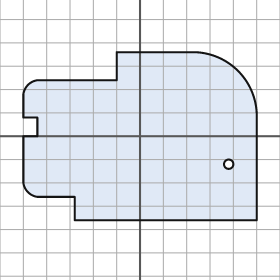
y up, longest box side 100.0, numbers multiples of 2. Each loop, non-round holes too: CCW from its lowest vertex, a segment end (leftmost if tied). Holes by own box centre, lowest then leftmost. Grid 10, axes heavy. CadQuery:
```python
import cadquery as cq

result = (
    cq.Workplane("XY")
    .moveTo(-28.0, -36.0)
    .lineTo(50.0, -36.0)
    .lineTo(50.0, 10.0)
    .threePointArc((42.0, 28.0), (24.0, 36.0))
    .lineTo(-10.0, 36.0)
    .lineTo(-10.0, 24.0)
    .lineTo(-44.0, 24.0)
    .threePointArc((-48.0, 22.0), (-50.0, 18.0))
    .lineTo(-50.0, 8.0)
    .lineTo(-44.0, 8.0)
    .lineTo(-44.0, 0.0)
    .lineTo(-50.0, 0.0)
    .lineTo(-50.0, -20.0)
    .threePointArc((-48.0, -24.0), (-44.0, -26.0))
    .lineTo(-28.0, -26.0)
    .close()
    .moveTo(38.0, -12.0)
    .circle(2.0)
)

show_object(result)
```